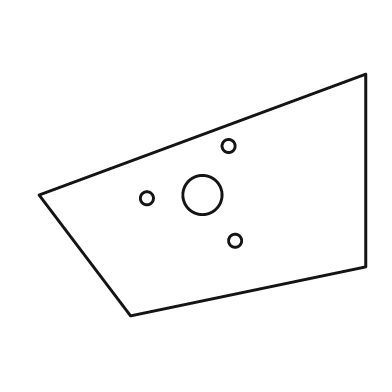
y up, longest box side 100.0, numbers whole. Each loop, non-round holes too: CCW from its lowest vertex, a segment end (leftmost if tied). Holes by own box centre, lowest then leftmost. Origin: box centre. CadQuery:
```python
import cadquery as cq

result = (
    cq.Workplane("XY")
    .moveTo(-22.0, -37.0)
    .lineTo(50.0, -22.0)
    .lineTo(50.0, 37.0)
    .lineTo(-50.0, 0.0)
    .close()
    .moveTo(10.0, -14.0)
    .circle(2.0)
    .moveTo(-17.0, -1.0)
    .circle(2.0)
    .moveTo(0.0, 0.0)
    .circle(6.0)
    .moveTo(8.0, 15.0)
    .circle(2.0)
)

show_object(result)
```